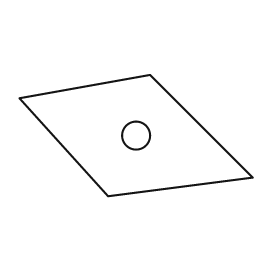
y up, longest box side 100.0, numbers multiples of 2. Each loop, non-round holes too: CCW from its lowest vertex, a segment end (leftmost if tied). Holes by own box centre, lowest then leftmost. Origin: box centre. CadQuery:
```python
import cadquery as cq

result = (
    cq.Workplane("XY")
    .moveTo(-12.0, -26.0)
    .lineTo(50.0, -18.0)
    .lineTo(6.0, 26.0)
    .lineTo(-50.0, 16.0)
    .close()
    .moveTo(0.0, 0.0)
    .circle(6.0)
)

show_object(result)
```